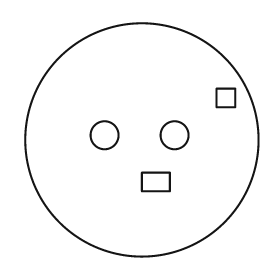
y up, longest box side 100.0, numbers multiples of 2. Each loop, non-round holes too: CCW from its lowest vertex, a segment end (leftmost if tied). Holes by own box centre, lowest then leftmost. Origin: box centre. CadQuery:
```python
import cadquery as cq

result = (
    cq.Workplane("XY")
    .moveTo(0.0, 0.0)
    .circle(50.0)
    .moveTo(0.0, -22.0)
    .lineTo(12.0, -22.0)
    .lineTo(12.0, -14.0)
    .lineTo(0.0, -14.0)
    .close()
    .moveTo(-16.0, 2.0)
    .circle(6.0)
    .moveTo(14.0, 2.0)
    .circle(6.0)
    .moveTo(32.0, 14.0)
    .lineTo(40.0, 14.0)
    .lineTo(40.0, 22.0)
    .lineTo(32.0, 22.0)
    .close()
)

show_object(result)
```